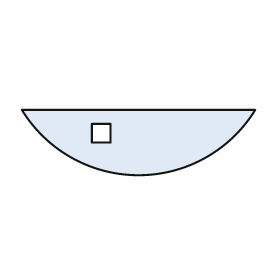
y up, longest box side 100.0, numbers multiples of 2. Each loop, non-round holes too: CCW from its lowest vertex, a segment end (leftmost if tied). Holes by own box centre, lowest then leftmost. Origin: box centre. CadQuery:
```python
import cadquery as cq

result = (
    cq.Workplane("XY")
    .moveTo(-50.0, 14.0)
    .threePointArc((0.0, -14.0), (50.0, 14.0))
    .close()
    .moveTo(-20.0, 0.0)
    .lineTo(-12.0, 0.0)
    .lineTo(-12.0, 8.0)
    .lineTo(-20.0, 8.0)
    .close()
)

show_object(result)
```